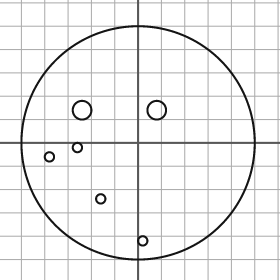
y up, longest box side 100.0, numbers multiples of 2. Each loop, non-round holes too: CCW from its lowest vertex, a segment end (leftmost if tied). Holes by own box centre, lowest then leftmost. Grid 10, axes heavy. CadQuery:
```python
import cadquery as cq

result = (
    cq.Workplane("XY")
    .moveTo(0.0, 0.0)
    .circle(50.0)
    .moveTo(2.0, -42.0)
    .circle(2.0)
    .moveTo(-16.0, -24.0)
    .circle(2.0)
    .moveTo(-38.0, -6.0)
    .circle(2.0)
    .moveTo(-26.0, -2.0)
    .circle(2.0)
    .moveTo(-24.0, 14.0)
    .circle(4.0)
    .moveTo(8.0, 14.0)
    .circle(4.0)
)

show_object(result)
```